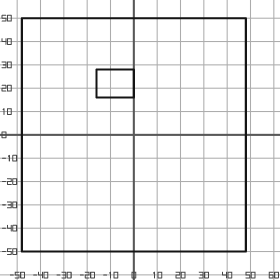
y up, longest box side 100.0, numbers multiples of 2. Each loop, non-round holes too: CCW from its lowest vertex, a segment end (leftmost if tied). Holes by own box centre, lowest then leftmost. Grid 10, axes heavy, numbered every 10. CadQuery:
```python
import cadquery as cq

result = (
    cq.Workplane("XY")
    .moveTo(-48.0, -50.0)
    .lineTo(48.0, -50.0)
    .lineTo(48.0, 50.0)
    .lineTo(-48.0, 50.0)
    .close()
    .moveTo(-16.0, 16.0)
    .lineTo(0.0, 16.0)
    .lineTo(0.0, 28.0)
    .lineTo(-16.0, 28.0)
    .close()
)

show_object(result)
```